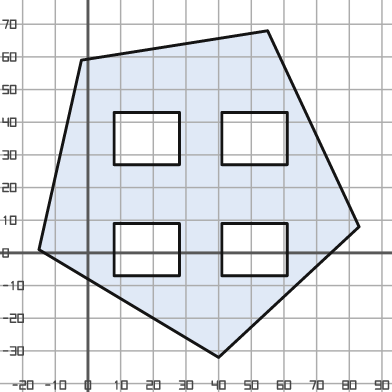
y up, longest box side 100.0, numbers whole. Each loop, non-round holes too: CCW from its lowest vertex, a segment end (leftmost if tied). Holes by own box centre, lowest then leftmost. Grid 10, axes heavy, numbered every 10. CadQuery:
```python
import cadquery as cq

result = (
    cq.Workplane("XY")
    .moveTo(40.0, -32.0)
    .lineTo(83.0, 8.0)
    .lineTo(55.0, 68.0)
    .lineTo(-2.0, 59.0)
    .lineTo(-15.0, 1.0)
    .close()
    .moveTo(8.0, -7.0)
    .lineTo(28.0, -7.0)
    .lineTo(28.0, 9.0)
    .lineTo(8.0, 9.0)
    .close()
    .moveTo(41.0, -7.0)
    .lineTo(61.0, -7.0)
    .lineTo(61.0, 9.0)
    .lineTo(41.0, 9.0)
    .close()
    .moveTo(8.0, 27.0)
    .lineTo(28.0, 27.0)
    .lineTo(28.0, 43.0)
    .lineTo(8.0, 43.0)
    .close()
    .moveTo(41.0, 27.0)
    .lineTo(61.0, 27.0)
    .lineTo(61.0, 43.0)
    .lineTo(41.0, 43.0)
    .close()
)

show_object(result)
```